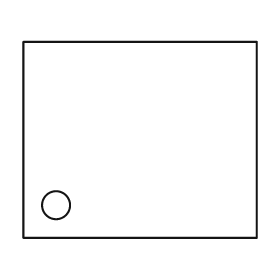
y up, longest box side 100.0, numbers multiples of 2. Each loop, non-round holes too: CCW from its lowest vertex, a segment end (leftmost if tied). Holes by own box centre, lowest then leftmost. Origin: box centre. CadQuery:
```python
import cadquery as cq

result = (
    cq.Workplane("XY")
    .moveTo(-50.0, -42.0)
    .lineTo(50.0, -42.0)
    .lineTo(50.0, 42.0)
    .lineTo(-50.0, 42.0)
    .close()
    .moveTo(-36.0, -28.0)
    .circle(6.0)
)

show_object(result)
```